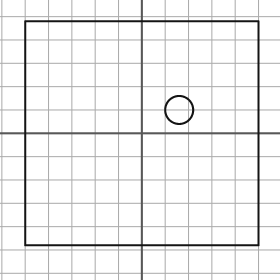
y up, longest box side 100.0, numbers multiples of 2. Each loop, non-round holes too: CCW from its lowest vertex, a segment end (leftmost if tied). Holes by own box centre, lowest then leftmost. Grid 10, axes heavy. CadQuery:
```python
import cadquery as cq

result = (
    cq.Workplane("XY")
    .moveTo(-50.0, -48.0)
    .lineTo(50.0, -48.0)
    .lineTo(50.0, 48.0)
    .lineTo(-50.0, 48.0)
    .close()
    .moveTo(16.0, 10.0)
    .circle(6.0)
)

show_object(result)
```